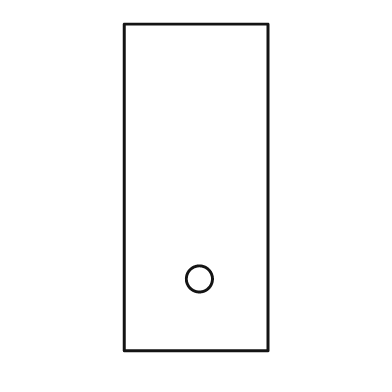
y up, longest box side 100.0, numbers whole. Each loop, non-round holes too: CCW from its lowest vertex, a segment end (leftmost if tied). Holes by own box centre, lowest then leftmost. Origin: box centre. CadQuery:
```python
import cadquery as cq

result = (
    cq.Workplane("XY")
    .moveTo(-22.0, -50.0)
    .lineTo(22.0, -50.0)
    .lineTo(22.0, 50.0)
    .lineTo(-22.0, 50.0)
    .close()
    .moveTo(1.0, -28.0)
    .circle(4.0)
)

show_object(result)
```